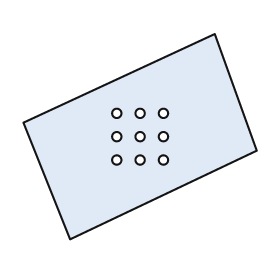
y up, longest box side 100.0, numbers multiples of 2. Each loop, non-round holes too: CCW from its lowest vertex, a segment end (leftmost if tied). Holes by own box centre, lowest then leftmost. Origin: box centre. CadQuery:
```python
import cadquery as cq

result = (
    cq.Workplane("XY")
    .moveTo(-30.0, -44.0)
    .lineTo(50.0, -6.0)
    .lineTo(32.0, 44.0)
    .lineTo(-50.0, 6.0)
    .close()
    .moveTo(-10.0, -10.0)
    .circle(2.0)
    .moveTo(0.0, -10.0)
    .circle(2.0)
    .moveTo(10.0, -10.0)
    .circle(2.0)
    .moveTo(-10.0, 0.0)
    .circle(2.0)
    .moveTo(0.0, 0.0)
    .circle(2.0)
    .moveTo(10.0, 0.0)
    .circle(2.0)
    .moveTo(-10.0, 10.0)
    .circle(2.0)
    .moveTo(0.0, 10.0)
    .circle(2.0)
    .moveTo(10.0, 10.0)
    .circle(2.0)
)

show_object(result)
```